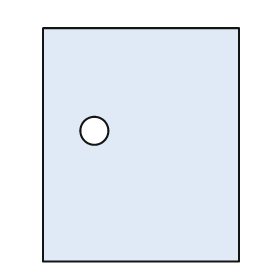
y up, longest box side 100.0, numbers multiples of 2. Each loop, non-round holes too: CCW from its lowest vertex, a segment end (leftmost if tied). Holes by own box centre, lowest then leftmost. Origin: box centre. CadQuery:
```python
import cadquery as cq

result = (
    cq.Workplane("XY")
    .moveTo(-42.0, -50.0)
    .lineTo(42.0, -50.0)
    .lineTo(42.0, 50.0)
    .lineTo(-42.0, 50.0)
    .close()
    .moveTo(-20.0, 6.0)
    .circle(6.0)
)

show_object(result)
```